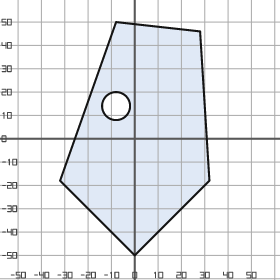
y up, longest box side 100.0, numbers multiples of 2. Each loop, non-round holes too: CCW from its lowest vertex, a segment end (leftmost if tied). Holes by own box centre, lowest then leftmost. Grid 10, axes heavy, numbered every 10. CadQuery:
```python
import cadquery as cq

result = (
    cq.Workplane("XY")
    .moveTo(0.0, -50.0)
    .lineTo(32.0, -18.0)
    .lineTo(28.0, 46.0)
    .lineTo(-8.0, 50.0)
    .lineTo(-32.0, -18.0)
    .close()
    .moveTo(-8.0, 14.0)
    .circle(6.0)
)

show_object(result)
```